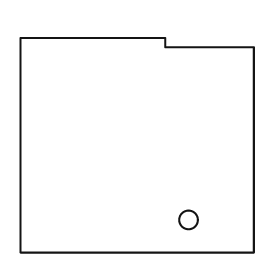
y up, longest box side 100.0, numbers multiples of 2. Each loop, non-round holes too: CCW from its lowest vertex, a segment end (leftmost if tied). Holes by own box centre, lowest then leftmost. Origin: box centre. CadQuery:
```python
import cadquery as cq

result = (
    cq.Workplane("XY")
    .moveTo(-50.0, -46.0)
    .lineTo(50.0, -46.0)
    .lineTo(50.0, 42.0)
    .lineTo(12.0, 42.0)
    .lineTo(12.0, 46.0)
    .lineTo(-50.0, 46.0)
    .close()
    .moveTo(22.0, -32.0)
    .circle(4.0)
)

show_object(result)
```